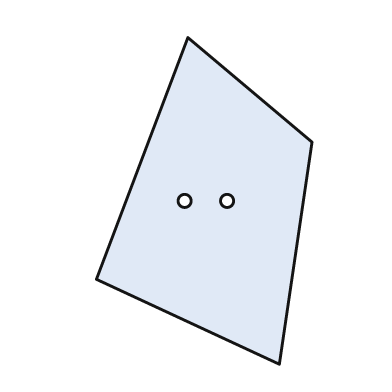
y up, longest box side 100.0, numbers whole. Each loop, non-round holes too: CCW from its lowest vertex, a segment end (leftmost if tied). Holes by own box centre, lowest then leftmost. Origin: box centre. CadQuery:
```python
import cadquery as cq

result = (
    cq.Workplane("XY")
    .moveTo(23.0, -50.0)
    .lineTo(33.0, 18.0)
    .lineTo(-5.0, 50.0)
    .lineTo(-33.0, -24.0)
    .close()
    .moveTo(-6.0, 0.0)
    .circle(2.0)
    .moveTo(7.0, 0.0)
    .circle(2.0)
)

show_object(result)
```